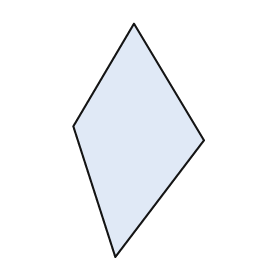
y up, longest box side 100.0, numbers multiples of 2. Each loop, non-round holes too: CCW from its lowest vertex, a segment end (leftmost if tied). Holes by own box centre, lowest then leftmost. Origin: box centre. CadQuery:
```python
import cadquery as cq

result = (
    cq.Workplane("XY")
    .moveTo(-10.0, -50.0)
    .lineTo(28.0, 0.0)
    .lineTo(-2.0, 50.0)
    .lineTo(-28.0, 6.0)
    .close()
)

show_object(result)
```